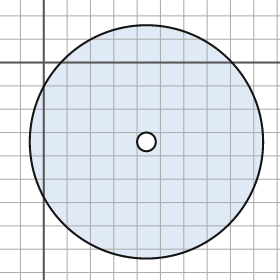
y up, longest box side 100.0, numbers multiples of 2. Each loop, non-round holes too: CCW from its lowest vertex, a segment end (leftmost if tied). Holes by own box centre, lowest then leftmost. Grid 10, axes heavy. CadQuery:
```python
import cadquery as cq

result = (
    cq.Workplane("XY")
    .moveTo(44.0, -34.0)
    .circle(50.0)
    .moveTo(44.0, -34.0)
    .circle(4.0)
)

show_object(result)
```